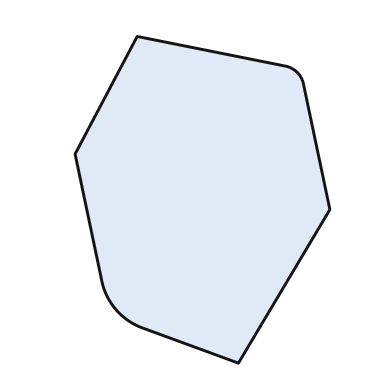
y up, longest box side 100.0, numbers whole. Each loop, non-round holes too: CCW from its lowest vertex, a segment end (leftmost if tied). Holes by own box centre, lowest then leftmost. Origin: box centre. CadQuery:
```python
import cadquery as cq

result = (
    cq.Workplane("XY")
    .moveTo(11.0, -50.0)
    .lineTo(39.0, -3.0)
    .lineTo(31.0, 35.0)
    .threePointArc((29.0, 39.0), (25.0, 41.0))
    .lineTo(-20.0, 50.0)
    .lineTo(-39.0, 14.0)
    .lineTo(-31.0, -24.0)
    .threePointArc((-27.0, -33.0), (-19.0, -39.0))
    .close()
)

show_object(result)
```